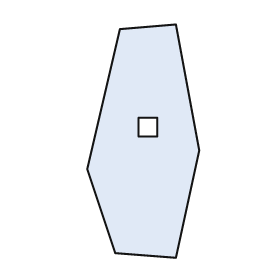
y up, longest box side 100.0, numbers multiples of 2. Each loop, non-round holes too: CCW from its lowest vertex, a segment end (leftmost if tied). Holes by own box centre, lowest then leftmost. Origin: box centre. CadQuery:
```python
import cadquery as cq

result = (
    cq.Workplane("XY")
    .moveTo(14.0, -50.0)
    .lineTo(24.0, -4.0)
    .lineTo(14.0, 50.0)
    .lineTo(-10.0, 48.0)
    .lineTo(-24.0, -12.0)
    .lineTo(-12.0, -48.0)
    .close()
    .moveTo(-2.0, 2.0)
    .lineTo(6.0, 2.0)
    .lineTo(6.0, 10.0)
    .lineTo(-2.0, 10.0)
    .close()
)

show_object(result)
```